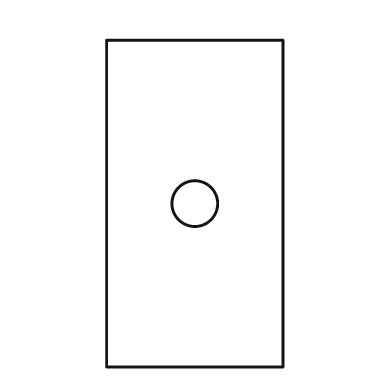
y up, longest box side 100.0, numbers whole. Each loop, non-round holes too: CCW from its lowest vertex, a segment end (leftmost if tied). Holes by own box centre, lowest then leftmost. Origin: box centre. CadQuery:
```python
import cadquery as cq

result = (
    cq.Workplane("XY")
    .moveTo(-27.0, -50.0)
    .lineTo(27.0, -50.0)
    .lineTo(27.0, 50.0)
    .lineTo(-27.0, 50.0)
    .close()
    .moveTo(0.0, 0.0)
    .circle(7.0)
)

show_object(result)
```